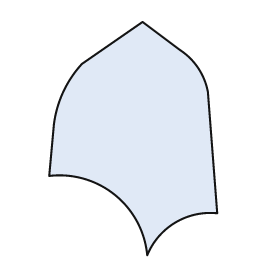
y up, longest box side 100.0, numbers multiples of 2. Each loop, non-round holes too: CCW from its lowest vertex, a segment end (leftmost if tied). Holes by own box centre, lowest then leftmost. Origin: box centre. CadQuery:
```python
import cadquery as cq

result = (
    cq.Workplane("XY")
    .moveTo(6.0, -50.0)
    .threePointArc((18.0, -36.0), (36.0, -32.0))
    .lineTo(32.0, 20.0)
    .threePointArc((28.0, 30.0), (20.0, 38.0))
    .lineTo(4.0, 50.0)
    .lineTo(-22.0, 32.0)
    .threePointArc((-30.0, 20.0), (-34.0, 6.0))
    .lineTo(-36.0, -16.0)
    .threePointArc((-8.0, -24.0), (6.0, -50.0))
    .close()
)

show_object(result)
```